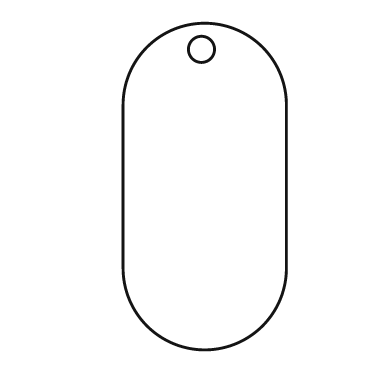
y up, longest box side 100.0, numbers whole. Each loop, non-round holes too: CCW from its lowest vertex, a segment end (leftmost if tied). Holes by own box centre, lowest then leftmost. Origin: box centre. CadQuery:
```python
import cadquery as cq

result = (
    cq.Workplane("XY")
    .moveTo(-25.0, -25.0)
    .threePointArc((0.0, -50.0), (25.0, -25.0))
    .lineTo(25.0, 25.0)
    .threePointArc((0.0, 50.0), (-25.0, 25.0))
    .close()
    .moveTo(-1.0, 42.0)
    .circle(4.0)
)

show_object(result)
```